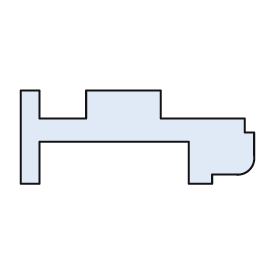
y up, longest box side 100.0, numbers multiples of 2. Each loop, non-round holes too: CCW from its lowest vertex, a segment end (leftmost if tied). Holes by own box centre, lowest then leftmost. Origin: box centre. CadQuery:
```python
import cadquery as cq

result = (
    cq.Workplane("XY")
    .moveTo(-50.0, -20.0)
    .lineTo(-42.0, -20.0)
    .lineTo(-42.0, -2.0)
    .lineTo(22.0, -2.0)
    .lineTo(22.0, -20.0)
    .lineTo(32.0, -20.0)
    .lineTo(32.0, -16.0)
    .lineTo(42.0, -16.0)
    .threePointArc((48.0, -14.0), (50.0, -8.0))
    .lineTo(50.0, 2.0)
    .lineTo(46.0, 2.0)
    .lineTo(46.0, 8.0)
    .lineTo(10.0, 8.0)
    .lineTo(10.0, 20.0)
    .lineTo(-22.0, 20.0)
    .lineTo(-22.0, 8.0)
    .lineTo(-42.0, 8.0)
    .lineTo(-42.0, 20.0)
    .lineTo(-50.0, 20.0)
    .close()
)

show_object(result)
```